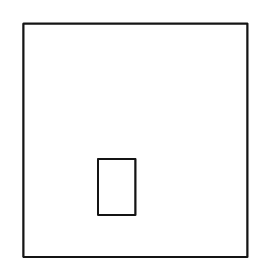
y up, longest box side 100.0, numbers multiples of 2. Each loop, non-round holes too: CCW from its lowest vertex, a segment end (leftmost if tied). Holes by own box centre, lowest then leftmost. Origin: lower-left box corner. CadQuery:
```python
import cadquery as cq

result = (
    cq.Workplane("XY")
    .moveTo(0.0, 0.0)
    .lineTo(96.0, 0.0)
    .lineTo(96.0, 100.0)
    .lineTo(0.0, 100.0)
    .close()
    .moveTo(32.0, 18.0)
    .lineTo(48.0, 18.0)
    .lineTo(48.0, 42.0)
    .lineTo(32.0, 42.0)
    .close()
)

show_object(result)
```